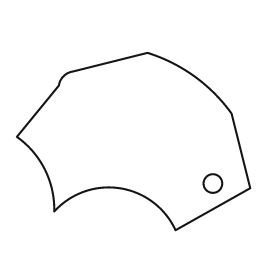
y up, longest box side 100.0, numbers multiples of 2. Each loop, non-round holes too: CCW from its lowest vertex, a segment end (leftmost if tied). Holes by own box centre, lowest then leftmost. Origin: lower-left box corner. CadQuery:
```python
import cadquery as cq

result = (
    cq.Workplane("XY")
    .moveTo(68.0, 0.0)
    .lineTo(100.0, 18.0)
    .lineTo(92.0, 50.0)
    .threePointArc((76.0, 66.0), (56.0, 76.0))
    .lineTo(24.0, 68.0)
    .threePointArc((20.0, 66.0), (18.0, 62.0))
    .lineTo(0.0, 40.0)
    .threePointArc((12.0, 26.0), (16.0, 8.0))
    .threePointArc((44.0, 18.0), (68.0, 0.0))
    .close()
    .moveTo(84.0, 20.0)
    .circle(4.0)
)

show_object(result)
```